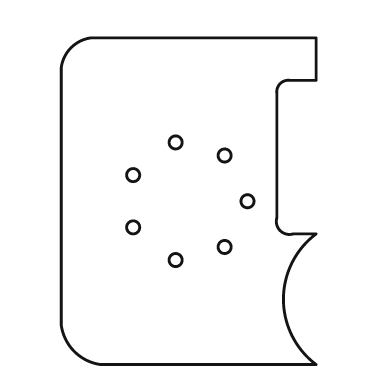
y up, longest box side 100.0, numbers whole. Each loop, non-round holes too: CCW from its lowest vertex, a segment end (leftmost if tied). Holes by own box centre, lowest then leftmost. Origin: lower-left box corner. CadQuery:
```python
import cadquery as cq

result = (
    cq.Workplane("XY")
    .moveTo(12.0, 0.0)
    .lineTo(78.0, 0.0)
    .threePointArc((68.0, 20.0), (78.0, 40.0))
    .lineTo(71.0, 40.0)
    .threePointArc((67.0, 41.0), (66.0, 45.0))
    .lineTo(66.0, 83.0)
    .threePointArc((67.0, 86.0), (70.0, 87.0))
    .lineTo(78.0, 87.0)
    .lineTo(78.0, 100.0)
    .lineTo(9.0, 100.0)
    .threePointArc((3.0, 97.0), (0.0, 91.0))
    .lineTo(0.0, 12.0)
    .threePointArc((4.0, 4.0), (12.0, 0.0))
    .close()
    .moveTo(35.0, 32.0)
    .circle(2.0)
    .moveTo(50.0, 36.0)
    .circle(2.0)
    .moveTo(22.0, 42.0)
    .circle(2.0)
    .moveTo(57.0, 50.0)
    .circle(2.0)
    .moveTo(22.0, 58.0)
    .circle(2.0)
    .moveTo(50.0, 64.0)
    .circle(2.0)
    .moveTo(35.0, 68.0)
    .circle(2.0)
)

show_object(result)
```